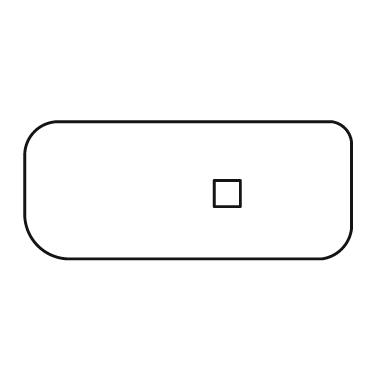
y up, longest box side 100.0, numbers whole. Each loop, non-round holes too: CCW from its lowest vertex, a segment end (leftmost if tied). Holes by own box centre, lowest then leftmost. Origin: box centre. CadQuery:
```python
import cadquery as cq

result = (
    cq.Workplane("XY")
    .moveTo(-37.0, -21.0)
    .lineTo(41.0, -21.0)
    .threePointArc((47.0, -18.0), (50.0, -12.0))
    .lineTo(50.0, 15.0)
    .threePointArc((48.0, 19.0), (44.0, 21.0))
    .lineTo(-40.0, 21.0)
    .threePointArc((-47.0, 18.0), (-50.0, 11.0))
    .lineTo(-50.0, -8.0)
    .threePointArc((-46.0, -17.0), (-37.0, -21.0))
    .close()
    .moveTo(8.0, -5.0)
    .lineTo(16.0, -5.0)
    .lineTo(16.0, 3.0)
    .lineTo(8.0, 3.0)
    .close()
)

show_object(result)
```